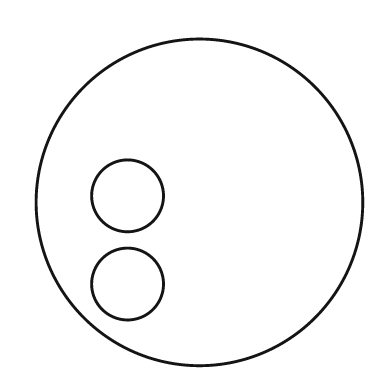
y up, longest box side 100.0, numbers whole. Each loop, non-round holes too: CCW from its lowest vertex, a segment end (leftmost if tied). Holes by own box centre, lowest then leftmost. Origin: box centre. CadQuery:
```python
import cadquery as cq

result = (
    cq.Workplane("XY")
    .moveTo(0.0, 0.0)
    .circle(50.0)
    .moveTo(-22.0, -25.0)
    .circle(11.0)
    .moveTo(-22.0, 2.0)
    .circle(11.0)
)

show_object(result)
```